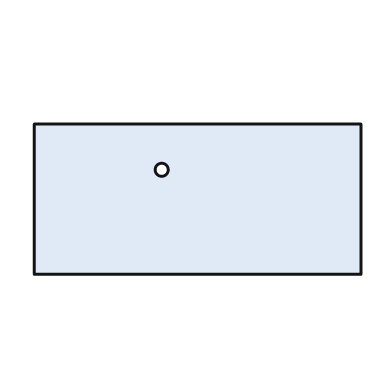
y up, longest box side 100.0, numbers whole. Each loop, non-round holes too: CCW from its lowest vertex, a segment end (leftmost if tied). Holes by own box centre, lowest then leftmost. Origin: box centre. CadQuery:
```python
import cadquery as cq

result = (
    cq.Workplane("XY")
    .moveTo(-50.0, -23.0)
    .lineTo(50.0, -23.0)
    .lineTo(50.0, 23.0)
    .lineTo(-50.0, 23.0)
    .close()
    .moveTo(-11.0, 9.0)
    .circle(2.0)
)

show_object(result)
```